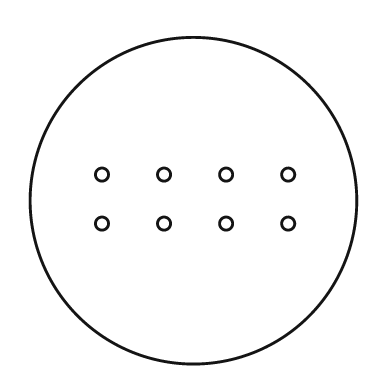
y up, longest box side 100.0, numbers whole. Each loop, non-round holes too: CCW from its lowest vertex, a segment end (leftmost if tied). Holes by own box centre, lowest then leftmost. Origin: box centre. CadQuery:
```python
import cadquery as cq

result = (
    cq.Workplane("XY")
    .moveTo(0.0, 0.0)
    .circle(50.0)
    .moveTo(-28.0, -7.0)
    .circle(2.0)
    .moveTo(-9.0, -7.0)
    .circle(2.0)
    .moveTo(10.0, -7.0)
    .circle(2.0)
    .moveTo(29.0, -7.0)
    .circle(2.0)
    .moveTo(-28.0, 8.0)
    .circle(2.0)
    .moveTo(-9.0, 8.0)
    .circle(2.0)
    .moveTo(10.0, 8.0)
    .circle(2.0)
    .moveTo(29.0, 8.0)
    .circle(2.0)
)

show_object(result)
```